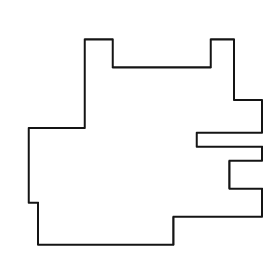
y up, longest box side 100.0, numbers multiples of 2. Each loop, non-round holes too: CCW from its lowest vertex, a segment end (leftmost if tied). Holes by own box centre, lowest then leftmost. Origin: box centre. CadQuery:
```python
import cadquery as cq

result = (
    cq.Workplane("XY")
    .moveTo(-46.0, -44.0)
    .lineTo(12.0, -44.0)
    .lineTo(12.0, -32.0)
    .lineTo(50.0, -32.0)
    .lineTo(50.0, -20.0)
    .lineTo(36.0, -20.0)
    .lineTo(36.0, -8.0)
    .lineTo(50.0, -8.0)
    .lineTo(50.0, -2.0)
    .lineTo(22.0, -2.0)
    .lineTo(22.0, 4.0)
    .lineTo(50.0, 4.0)
    .lineTo(50.0, 18.0)
    .lineTo(38.0, 18.0)
    .lineTo(38.0, 44.0)
    .lineTo(28.0, 44.0)
    .lineTo(28.0, 32.0)
    .lineTo(-14.0, 32.0)
    .lineTo(-14.0, 44.0)
    .lineTo(-26.0, 44.0)
    .lineTo(-26.0, 6.0)
    .lineTo(-50.0, 6.0)
    .lineTo(-50.0, -26.0)
    .lineTo(-46.0, -26.0)
    .close()
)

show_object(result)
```